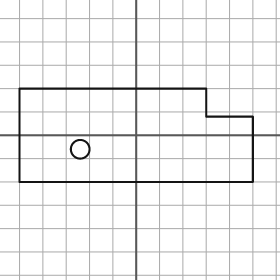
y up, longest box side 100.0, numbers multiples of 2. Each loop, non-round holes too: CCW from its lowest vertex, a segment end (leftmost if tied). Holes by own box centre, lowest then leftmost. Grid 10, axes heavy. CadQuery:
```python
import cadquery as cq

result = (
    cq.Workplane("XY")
    .moveTo(-50.0, -20.0)
    .lineTo(50.0, -20.0)
    .lineTo(50.0, 8.0)
    .lineTo(30.0, 8.0)
    .lineTo(30.0, 20.0)
    .lineTo(-50.0, 20.0)
    .close()
    .moveTo(-24.0, -6.0)
    .circle(4.0)
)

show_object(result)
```